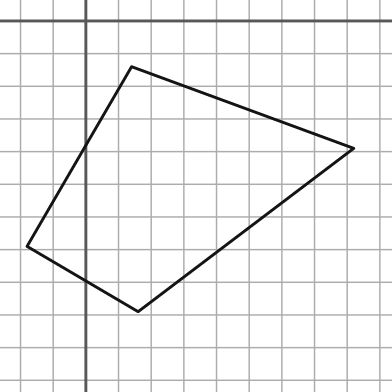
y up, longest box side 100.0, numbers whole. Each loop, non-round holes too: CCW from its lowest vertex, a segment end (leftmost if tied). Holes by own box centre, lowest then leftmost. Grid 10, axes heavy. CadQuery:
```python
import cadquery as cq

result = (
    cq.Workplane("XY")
    .moveTo(16.0, -89.0)
    .lineTo(82.0, -39.0)
    .lineTo(14.0, -14.0)
    .lineTo(-18.0, -69.0)
    .close()
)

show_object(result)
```